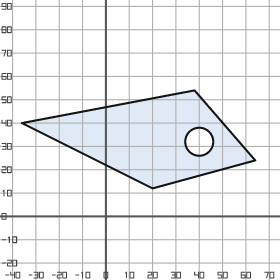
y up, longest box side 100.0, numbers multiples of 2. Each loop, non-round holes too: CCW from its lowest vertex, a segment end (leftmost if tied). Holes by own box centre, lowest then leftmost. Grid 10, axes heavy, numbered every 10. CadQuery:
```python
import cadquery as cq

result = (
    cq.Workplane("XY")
    .moveTo(20.0, 12.0)
    .lineTo(64.0, 24.0)
    .lineTo(38.0, 54.0)
    .lineTo(-36.0, 40.0)
    .close()
    .moveTo(40.0, 32.0)
    .circle(6.0)
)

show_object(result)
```